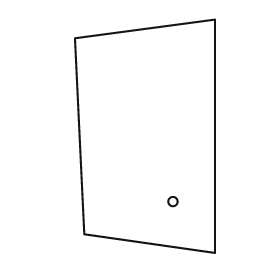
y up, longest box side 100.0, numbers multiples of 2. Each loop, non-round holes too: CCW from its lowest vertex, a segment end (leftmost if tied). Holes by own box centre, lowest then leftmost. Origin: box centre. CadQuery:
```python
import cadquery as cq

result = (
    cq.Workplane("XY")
    .moveTo(30.0, -50.0)
    .lineTo(30.0, 50.0)
    .lineTo(-30.0, 42.0)
    .lineTo(-26.0, -42.0)
    .close()
    .moveTo(12.0, -28.0)
    .circle(2.0)
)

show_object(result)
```